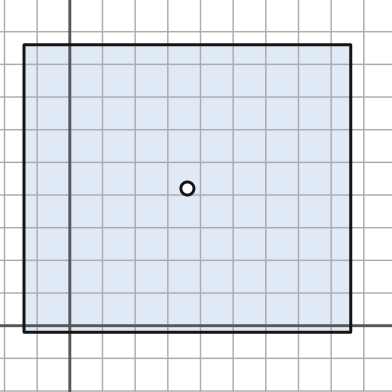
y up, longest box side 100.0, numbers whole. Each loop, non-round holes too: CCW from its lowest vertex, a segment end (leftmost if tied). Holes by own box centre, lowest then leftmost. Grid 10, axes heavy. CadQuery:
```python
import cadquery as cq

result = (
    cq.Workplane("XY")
    .moveTo(-14.0, -2.0)
    .lineTo(86.0, -2.0)
    .lineTo(86.0, 86.0)
    .lineTo(-14.0, 86.0)
    .close()
    .moveTo(36.0, 42.0)
    .circle(2.0)
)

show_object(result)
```